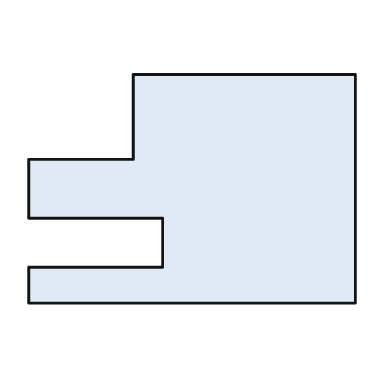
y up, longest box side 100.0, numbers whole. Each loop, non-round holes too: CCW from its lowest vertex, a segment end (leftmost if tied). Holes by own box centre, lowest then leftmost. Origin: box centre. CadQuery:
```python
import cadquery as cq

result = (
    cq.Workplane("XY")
    .moveTo(-50.0, -35.0)
    .lineTo(50.0, -35.0)
    .lineTo(50.0, 35.0)
    .lineTo(-18.0, 35.0)
    .lineTo(-18.0, 9.0)
    .lineTo(-50.0, 9.0)
    .lineTo(-50.0, -9.0)
    .lineTo(-9.0, -9.0)
    .lineTo(-9.0, -24.0)
    .lineTo(-50.0, -24.0)
    .close()
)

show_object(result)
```